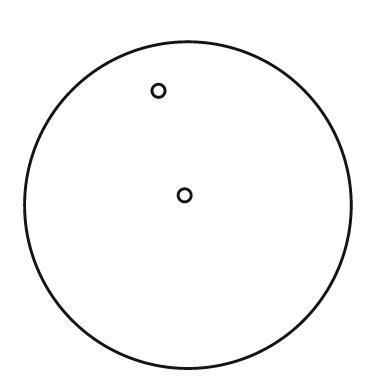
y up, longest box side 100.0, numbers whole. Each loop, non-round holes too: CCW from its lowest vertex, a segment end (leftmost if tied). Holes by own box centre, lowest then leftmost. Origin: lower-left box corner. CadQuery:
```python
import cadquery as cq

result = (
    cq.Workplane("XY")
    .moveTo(50.0, 50.0)
    .circle(50.0)
    .moveTo(49.0, 53.0)
    .circle(2.0)
    .moveTo(41.0, 85.0)
    .circle(2.0)
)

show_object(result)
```